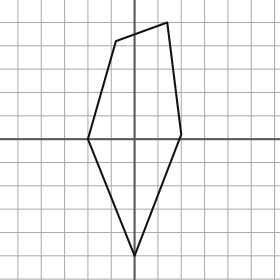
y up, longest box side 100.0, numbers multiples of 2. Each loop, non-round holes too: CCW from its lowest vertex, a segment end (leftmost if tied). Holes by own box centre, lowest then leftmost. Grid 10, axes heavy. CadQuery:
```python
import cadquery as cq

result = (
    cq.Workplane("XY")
    .moveTo(0.0, -50.0)
    .lineTo(20.0, 2.0)
    .lineTo(14.0, 50.0)
    .lineTo(-8.0, 42.0)
    .lineTo(-20.0, 0.0)
    .close()
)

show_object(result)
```